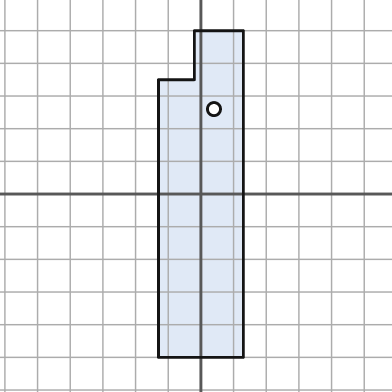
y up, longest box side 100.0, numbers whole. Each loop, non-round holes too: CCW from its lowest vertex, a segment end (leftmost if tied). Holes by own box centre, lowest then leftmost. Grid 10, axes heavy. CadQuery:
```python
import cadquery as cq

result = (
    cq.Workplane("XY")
    .moveTo(-13.0, -50.0)
    .lineTo(13.0, -50.0)
    .lineTo(13.0, 50.0)
    .lineTo(-2.0, 50.0)
    .lineTo(-2.0, 35.0)
    .lineTo(-13.0, 35.0)
    .close()
    .moveTo(4.0, 26.0)
    .circle(2.0)
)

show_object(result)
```